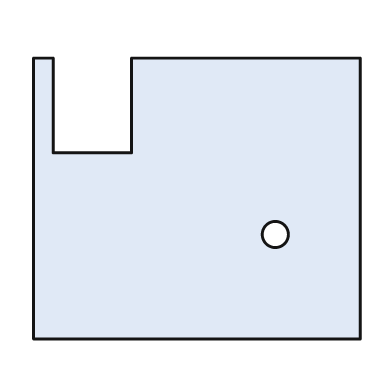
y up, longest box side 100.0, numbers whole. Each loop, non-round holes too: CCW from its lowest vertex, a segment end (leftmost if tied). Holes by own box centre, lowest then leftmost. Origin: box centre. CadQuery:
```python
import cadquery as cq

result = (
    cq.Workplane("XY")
    .moveTo(-50.0, -43.0)
    .lineTo(50.0, -43.0)
    .lineTo(50.0, 43.0)
    .lineTo(-20.0, 43.0)
    .lineTo(-20.0, 14.0)
    .lineTo(-44.0, 14.0)
    .lineTo(-44.0, 43.0)
    .lineTo(-50.0, 43.0)
    .close()
    .moveTo(24.0, -11.0)
    .circle(4.0)
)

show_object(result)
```